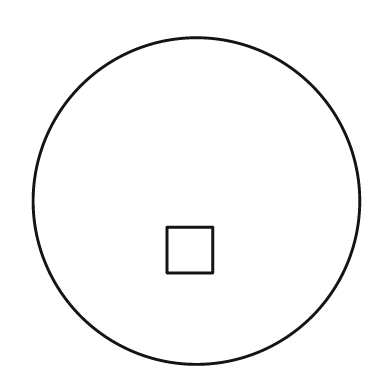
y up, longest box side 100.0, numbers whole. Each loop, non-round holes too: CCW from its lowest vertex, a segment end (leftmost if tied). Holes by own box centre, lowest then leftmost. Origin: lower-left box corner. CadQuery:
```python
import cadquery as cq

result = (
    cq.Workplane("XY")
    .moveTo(50.0, 50.0)
    .circle(50.0)
    .moveTo(41.0, 28.0)
    .lineTo(55.0, 28.0)
    .lineTo(55.0, 42.0)
    .lineTo(41.0, 42.0)
    .close()
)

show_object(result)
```